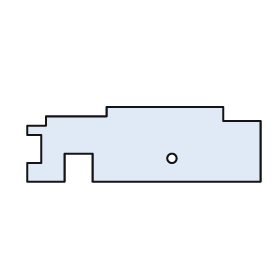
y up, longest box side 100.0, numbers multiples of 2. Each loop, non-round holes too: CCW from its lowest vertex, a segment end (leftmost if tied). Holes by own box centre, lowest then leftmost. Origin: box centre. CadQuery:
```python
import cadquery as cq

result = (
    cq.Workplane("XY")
    .moveTo(-50.0, -16.0)
    .lineTo(-34.0, -16.0)
    .lineTo(-34.0, -4.0)
    .lineTo(-22.0, -4.0)
    .lineTo(-22.0, -16.0)
    .lineTo(50.0, -16.0)
    .lineTo(50.0, 10.0)
    .lineTo(34.0, 10.0)
    .lineTo(34.0, 16.0)
    .lineTo(-16.0, 16.0)
    .lineTo(-16.0, 12.0)
    .lineTo(-42.0, 12.0)
    .lineTo(-42.0, 8.0)
    .lineTo(-50.0, 8.0)
    .lineTo(-50.0, 4.0)
    .lineTo(-44.0, 4.0)
    .lineTo(-44.0, -8.0)
    .lineTo(-50.0, -8.0)
    .close()
    .moveTo(12.0, -6.0)
    .circle(2.0)
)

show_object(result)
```